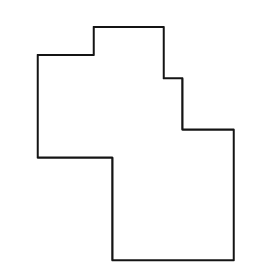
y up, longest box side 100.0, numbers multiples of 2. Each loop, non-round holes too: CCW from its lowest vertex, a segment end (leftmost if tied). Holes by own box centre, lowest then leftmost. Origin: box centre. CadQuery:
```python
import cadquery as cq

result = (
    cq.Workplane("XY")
    .moveTo(-10.0, -50.0)
    .lineTo(42.0, -50.0)
    .lineTo(42.0, 6.0)
    .lineTo(20.0, 6.0)
    .lineTo(20.0, 28.0)
    .lineTo(12.0, 28.0)
    .lineTo(12.0, 50.0)
    .lineTo(-18.0, 50.0)
    .lineTo(-18.0, 38.0)
    .lineTo(-42.0, 38.0)
    .lineTo(-42.0, -6.0)
    .lineTo(-10.0, -6.0)
    .close()
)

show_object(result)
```